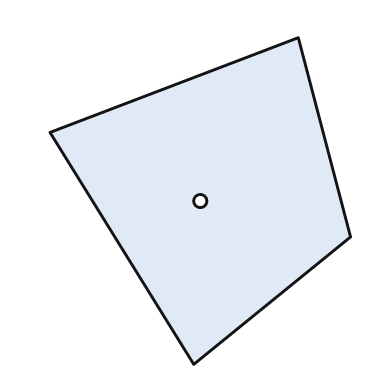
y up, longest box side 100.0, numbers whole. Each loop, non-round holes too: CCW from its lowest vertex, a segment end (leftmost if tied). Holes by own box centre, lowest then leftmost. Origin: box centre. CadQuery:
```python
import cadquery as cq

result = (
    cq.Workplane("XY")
    .moveTo(-2.0, -50.0)
    .lineTo(46.0, -11.0)
    .lineTo(30.0, 50.0)
    .lineTo(-46.0, 21.0)
    .close()
    .moveTo(0.0, 0.0)
    .circle(2.0)
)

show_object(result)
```